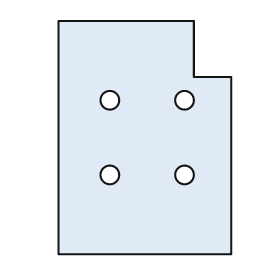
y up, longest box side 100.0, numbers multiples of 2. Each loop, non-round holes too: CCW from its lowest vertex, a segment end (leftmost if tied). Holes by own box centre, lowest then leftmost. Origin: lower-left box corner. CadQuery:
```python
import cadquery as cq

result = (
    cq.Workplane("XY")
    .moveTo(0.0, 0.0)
    .lineTo(74.0, 0.0)
    .lineTo(74.0, 76.0)
    .lineTo(58.0, 76.0)
    .lineTo(58.0, 100.0)
    .lineTo(0.0, 100.0)
    .close()
    .moveTo(22.0, 34.0)
    .circle(4.0)
    .moveTo(54.0, 34.0)
    .circle(4.0)
    .moveTo(22.0, 66.0)
    .circle(4.0)
    .moveTo(54.0, 66.0)
    .circle(4.0)
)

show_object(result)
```